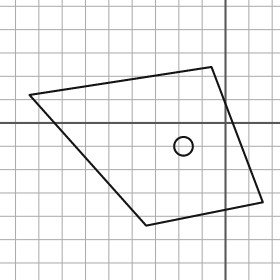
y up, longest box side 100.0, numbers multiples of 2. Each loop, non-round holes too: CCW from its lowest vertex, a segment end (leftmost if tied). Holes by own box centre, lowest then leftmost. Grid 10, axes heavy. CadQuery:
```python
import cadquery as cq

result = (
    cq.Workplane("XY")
    .moveTo(-34.0, -44.0)
    .lineTo(16.0, -34.0)
    .lineTo(-6.0, 24.0)
    .lineTo(-84.0, 12.0)
    .close()
    .moveTo(-18.0, -10.0)
    .circle(4.0)
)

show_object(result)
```